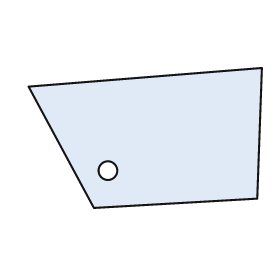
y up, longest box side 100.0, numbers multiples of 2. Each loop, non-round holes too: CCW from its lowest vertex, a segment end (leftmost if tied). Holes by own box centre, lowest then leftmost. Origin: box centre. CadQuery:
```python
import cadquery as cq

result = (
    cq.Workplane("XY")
    .moveTo(-22.0, -30.0)
    .lineTo(48.0, -26.0)
    .lineTo(50.0, 30.0)
    .lineTo(-50.0, 22.0)
    .close()
    .moveTo(-16.0, -14.0)
    .circle(4.0)
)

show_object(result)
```